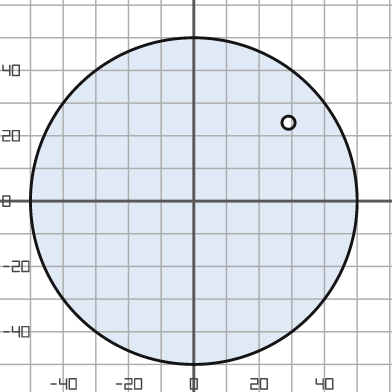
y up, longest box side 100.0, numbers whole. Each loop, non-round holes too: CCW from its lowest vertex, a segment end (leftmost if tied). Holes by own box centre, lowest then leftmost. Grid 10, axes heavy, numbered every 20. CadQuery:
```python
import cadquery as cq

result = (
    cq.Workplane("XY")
    .moveTo(0.0, 0.0)
    .circle(50.0)
    .moveTo(29.0, 24.0)
    .circle(2.0)
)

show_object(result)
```